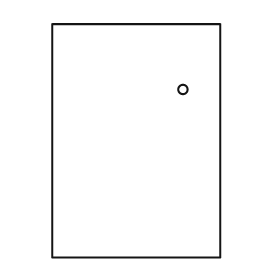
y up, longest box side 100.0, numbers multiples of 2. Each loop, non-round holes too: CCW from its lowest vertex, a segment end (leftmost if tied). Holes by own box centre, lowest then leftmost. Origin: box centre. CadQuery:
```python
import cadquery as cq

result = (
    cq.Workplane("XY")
    .moveTo(-36.0, -50.0)
    .lineTo(36.0, -50.0)
    .lineTo(36.0, 50.0)
    .lineTo(-36.0, 50.0)
    .close()
    .moveTo(20.0, 22.0)
    .circle(2.0)
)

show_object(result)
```